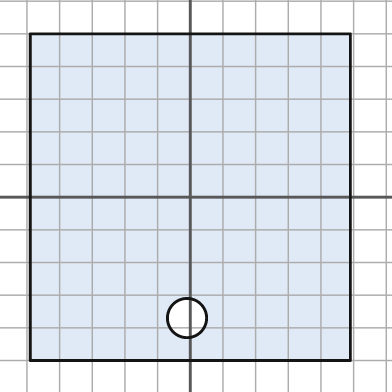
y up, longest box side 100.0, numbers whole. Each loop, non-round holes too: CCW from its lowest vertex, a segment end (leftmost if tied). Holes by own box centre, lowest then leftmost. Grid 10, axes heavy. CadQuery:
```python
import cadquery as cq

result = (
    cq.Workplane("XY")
    .moveTo(-49.0, -50.0)
    .lineTo(49.0, -50.0)
    .lineTo(49.0, 50.0)
    .lineTo(-49.0, 50.0)
    .close()
    .moveTo(-1.0, -37.0)
    .circle(6.0)
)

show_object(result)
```